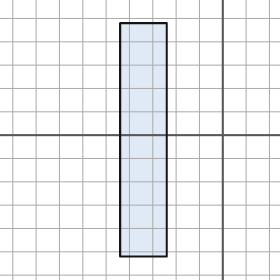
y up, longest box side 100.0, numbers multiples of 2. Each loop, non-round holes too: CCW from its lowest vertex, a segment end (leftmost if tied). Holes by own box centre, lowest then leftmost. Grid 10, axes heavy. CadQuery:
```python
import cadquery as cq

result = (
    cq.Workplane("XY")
    .moveTo(-44.0, -52.0)
    .lineTo(-24.0, -52.0)
    .lineTo(-24.0, 48.0)
    .lineTo(-44.0, 48.0)
    .close()
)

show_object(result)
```